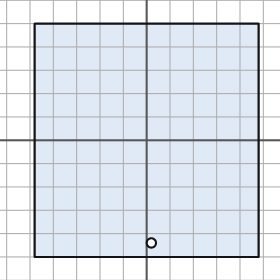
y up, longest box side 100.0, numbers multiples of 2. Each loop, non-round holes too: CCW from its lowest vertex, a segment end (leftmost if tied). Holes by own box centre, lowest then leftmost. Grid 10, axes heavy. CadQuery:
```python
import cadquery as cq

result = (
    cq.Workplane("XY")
    .moveTo(-48.0, -50.0)
    .lineTo(48.0, -50.0)
    .lineTo(48.0, 50.0)
    .lineTo(-48.0, 50.0)
    .close()
    .moveTo(2.0, -44.0)
    .circle(2.0)
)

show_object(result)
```